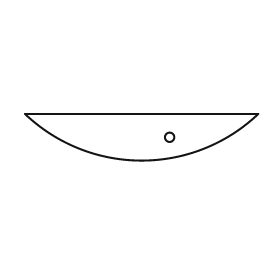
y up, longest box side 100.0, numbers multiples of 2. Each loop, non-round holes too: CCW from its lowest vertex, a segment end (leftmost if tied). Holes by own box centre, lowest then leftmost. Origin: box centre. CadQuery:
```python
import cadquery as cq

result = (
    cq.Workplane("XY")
    .moveTo(-50.0, 10.0)
    .threePointArc((0.0, -10.0), (50.0, 10.0))
    .close()
    .moveTo(12.0, 0.0)
    .circle(2.0)
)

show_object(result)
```